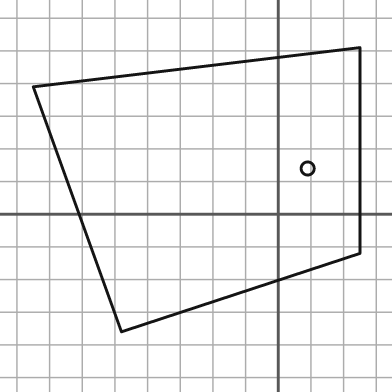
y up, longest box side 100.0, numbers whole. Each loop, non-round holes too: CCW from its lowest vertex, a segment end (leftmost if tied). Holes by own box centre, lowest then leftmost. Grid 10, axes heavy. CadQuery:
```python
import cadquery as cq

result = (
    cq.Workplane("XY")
    .moveTo(-48.0, -36.0)
    .lineTo(25.0, -12.0)
    .lineTo(25.0, 51.0)
    .lineTo(-75.0, 39.0)
    .close()
    .moveTo(9.0, 14.0)
    .circle(2.0)
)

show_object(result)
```